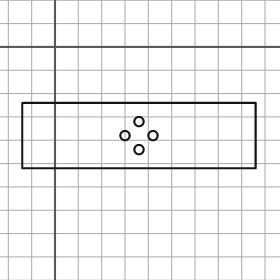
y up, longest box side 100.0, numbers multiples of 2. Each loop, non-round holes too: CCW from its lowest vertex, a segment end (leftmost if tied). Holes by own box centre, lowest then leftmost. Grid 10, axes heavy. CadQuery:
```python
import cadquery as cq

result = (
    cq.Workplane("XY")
    .moveTo(-14.0, -52.0)
    .lineTo(86.0, -52.0)
    .lineTo(86.0, -24.0)
    .lineTo(-14.0, -24.0)
    .close()
    .moveTo(36.0, -44.0)
    .circle(2.0)
    .moveTo(30.0, -38.0)
    .circle(2.0)
    .moveTo(42.0, -38.0)
    .circle(2.0)
    .moveTo(36.0, -32.0)
    .circle(2.0)
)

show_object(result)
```